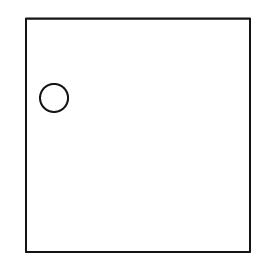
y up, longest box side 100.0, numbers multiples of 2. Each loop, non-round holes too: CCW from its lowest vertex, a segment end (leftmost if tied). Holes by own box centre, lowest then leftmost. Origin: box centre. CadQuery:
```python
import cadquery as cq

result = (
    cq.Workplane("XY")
    .moveTo(-48.0, -50.0)
    .lineTo(48.0, -50.0)
    .lineTo(48.0, 50.0)
    .lineTo(-48.0, 50.0)
    .close()
    .moveTo(-36.0, 16.0)
    .circle(6.0)
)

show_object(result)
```